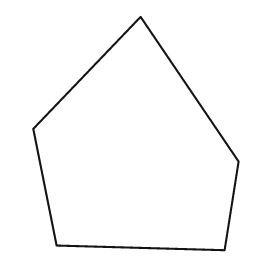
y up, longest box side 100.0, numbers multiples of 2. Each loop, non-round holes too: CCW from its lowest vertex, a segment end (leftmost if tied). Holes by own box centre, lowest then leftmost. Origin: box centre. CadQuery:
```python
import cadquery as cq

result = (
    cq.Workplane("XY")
    .moveTo(38.0, -50.0)
    .lineTo(44.0, -12.0)
    .lineTo(2.0, 50.0)
    .lineTo(-44.0, 2.0)
    .lineTo(-34.0, -48.0)
    .close()
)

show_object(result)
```